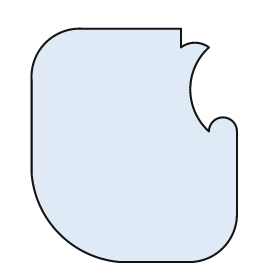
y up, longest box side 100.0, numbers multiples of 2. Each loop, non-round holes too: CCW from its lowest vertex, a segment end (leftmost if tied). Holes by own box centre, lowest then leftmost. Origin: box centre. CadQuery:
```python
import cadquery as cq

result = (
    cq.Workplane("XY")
    .moveTo(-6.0, -50.0)
    .lineTo(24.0, -50.0)
    .threePointArc((38.0, -44.0), (44.0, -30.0))
    .lineTo(44.0, 6.0)
    .threePointArc((38.0, 12.0), (32.0, 6.0))
    .threePointArc((24.0, 24.0), (32.0, 42.0))
    .threePointArc((26.0, 44.0), (20.0, 42.0))
    .lineTo(20.0, 50.0)
    .lineTo(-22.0, 50.0)
    .threePointArc((-38.0, 44.0), (-44.0, 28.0))
    .lineTo(-44.0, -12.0)
    .threePointArc((-32.0, -38.0), (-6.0, -50.0))
    .close()
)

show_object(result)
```